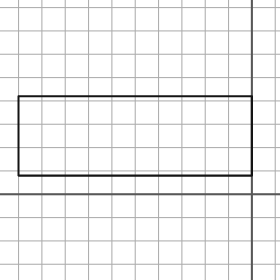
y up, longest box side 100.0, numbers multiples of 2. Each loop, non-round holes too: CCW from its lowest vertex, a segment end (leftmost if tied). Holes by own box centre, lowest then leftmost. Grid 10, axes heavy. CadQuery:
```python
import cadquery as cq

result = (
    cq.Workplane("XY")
    .moveTo(-100.0, 8.0)
    .lineTo(0.0, 8.0)
    .lineTo(0.0, 42.0)
    .lineTo(-100.0, 42.0)
    .close()
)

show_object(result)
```